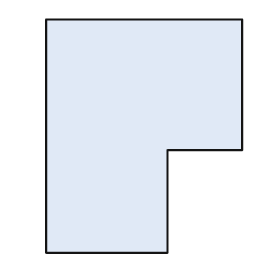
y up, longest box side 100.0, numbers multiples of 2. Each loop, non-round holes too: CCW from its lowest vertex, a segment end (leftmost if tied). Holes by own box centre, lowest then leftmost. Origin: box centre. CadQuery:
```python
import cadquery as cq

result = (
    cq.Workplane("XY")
    .moveTo(-42.0, -50.0)
    .lineTo(10.0, -50.0)
    .lineTo(10.0, -6.0)
    .lineTo(42.0, -6.0)
    .lineTo(42.0, 50.0)
    .lineTo(-42.0, 50.0)
    .close()
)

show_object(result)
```